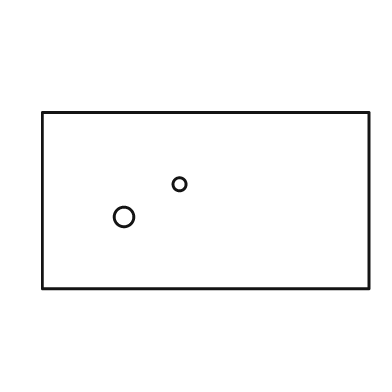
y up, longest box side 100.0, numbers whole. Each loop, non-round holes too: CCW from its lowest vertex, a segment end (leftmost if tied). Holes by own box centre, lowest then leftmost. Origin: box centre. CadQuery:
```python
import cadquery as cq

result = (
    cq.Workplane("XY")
    .moveTo(-50.0, -27.0)
    .lineTo(50.0, -27.0)
    .lineTo(50.0, 27.0)
    .lineTo(-50.0, 27.0)
    .close()
    .moveTo(-25.0, -5.0)
    .circle(3.0)
    .moveTo(-8.0, 5.0)
    .circle(2.0)
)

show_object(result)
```